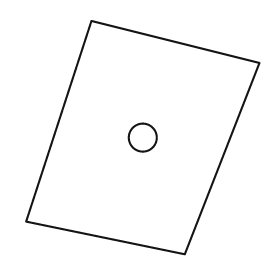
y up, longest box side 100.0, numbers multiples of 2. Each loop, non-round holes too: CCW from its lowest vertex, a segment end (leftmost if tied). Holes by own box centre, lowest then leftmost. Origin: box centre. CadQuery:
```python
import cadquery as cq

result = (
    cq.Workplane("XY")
    .moveTo(18.0, -50.0)
    .lineTo(50.0, 32.0)
    .lineTo(-22.0, 50.0)
    .lineTo(-50.0, -36.0)
    .close()
    .moveTo(0.0, 0.0)
    .circle(6.0)
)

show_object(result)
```